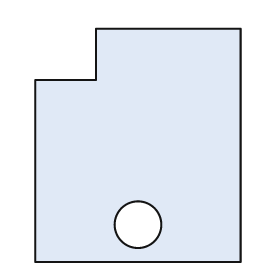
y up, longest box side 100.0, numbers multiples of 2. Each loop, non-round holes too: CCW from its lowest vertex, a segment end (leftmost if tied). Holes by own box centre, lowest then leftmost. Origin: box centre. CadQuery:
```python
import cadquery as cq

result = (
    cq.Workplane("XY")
    .moveTo(-44.0, -50.0)
    .lineTo(44.0, -50.0)
    .lineTo(44.0, 50.0)
    .lineTo(-18.0, 50.0)
    .lineTo(-18.0, 28.0)
    .lineTo(-44.0, 28.0)
    .close()
    .moveTo(0.0, -34.0)
    .circle(10.0)
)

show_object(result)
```